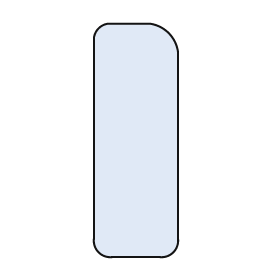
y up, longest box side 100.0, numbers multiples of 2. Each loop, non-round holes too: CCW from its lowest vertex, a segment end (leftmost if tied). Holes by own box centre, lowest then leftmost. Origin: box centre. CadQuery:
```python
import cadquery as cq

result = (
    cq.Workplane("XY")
    .moveTo(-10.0, -50.0)
    .lineTo(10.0, -50.0)
    .threePointArc((16.0, -48.0), (18.0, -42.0))
    .lineTo(18.0, 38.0)
    .threePointArc((14.0, 46.0), (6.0, 50.0))
    .lineTo(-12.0, 50.0)
    .threePointArc((-16.0, 48.0), (-18.0, 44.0))
    .lineTo(-18.0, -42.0)
    .threePointArc((-16.0, -48.0), (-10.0, -50.0))
    .close()
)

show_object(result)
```